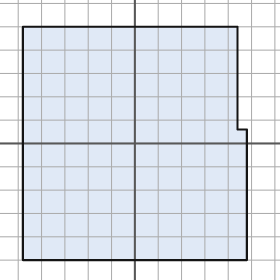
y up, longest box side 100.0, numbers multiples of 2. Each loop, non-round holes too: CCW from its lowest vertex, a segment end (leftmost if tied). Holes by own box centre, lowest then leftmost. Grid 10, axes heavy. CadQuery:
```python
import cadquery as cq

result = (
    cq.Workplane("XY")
    .moveTo(-48.0, -50.0)
    .lineTo(48.0, -50.0)
    .lineTo(48.0, 6.0)
    .lineTo(44.0, 6.0)
    .lineTo(44.0, 50.0)
    .lineTo(-48.0, 50.0)
    .close()
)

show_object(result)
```